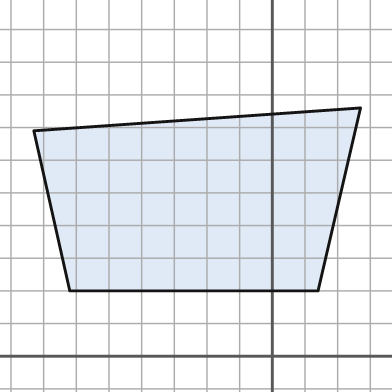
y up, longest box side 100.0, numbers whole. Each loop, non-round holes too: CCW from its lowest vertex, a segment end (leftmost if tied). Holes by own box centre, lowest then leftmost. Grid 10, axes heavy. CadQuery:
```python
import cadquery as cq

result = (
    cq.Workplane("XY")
    .moveTo(-62.0, 20.0)
    .lineTo(14.0, 20.0)
    .lineTo(27.0, 76.0)
    .lineTo(-73.0, 69.0)
    .close()
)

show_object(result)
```